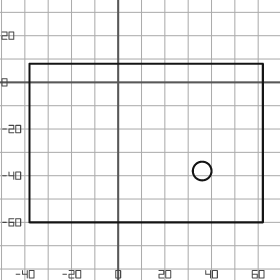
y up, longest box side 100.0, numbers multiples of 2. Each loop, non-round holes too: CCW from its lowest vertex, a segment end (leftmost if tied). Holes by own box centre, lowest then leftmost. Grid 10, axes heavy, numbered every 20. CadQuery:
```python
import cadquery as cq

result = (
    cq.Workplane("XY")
    .moveTo(-38.0, -60.0)
    .lineTo(62.0, -60.0)
    .lineTo(62.0, 8.0)
    .lineTo(-38.0, 8.0)
    .close()
    .moveTo(36.0, -38.0)
    .circle(4.0)
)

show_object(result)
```